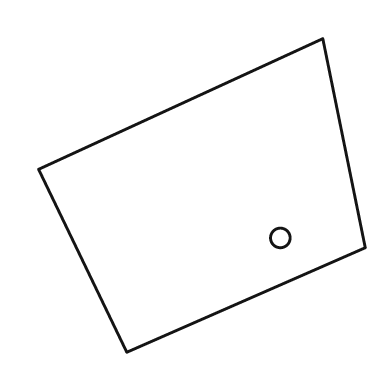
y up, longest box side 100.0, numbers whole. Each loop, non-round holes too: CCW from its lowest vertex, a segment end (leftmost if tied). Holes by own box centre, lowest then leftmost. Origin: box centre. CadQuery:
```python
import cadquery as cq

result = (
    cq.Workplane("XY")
    .moveTo(-23.0, -48.0)
    .lineTo(50.0, -16.0)
    .lineTo(37.0, 48.0)
    .lineTo(-50.0, 8.0)
    .close()
    .moveTo(24.0, -13.0)
    .circle(3.0)
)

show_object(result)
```